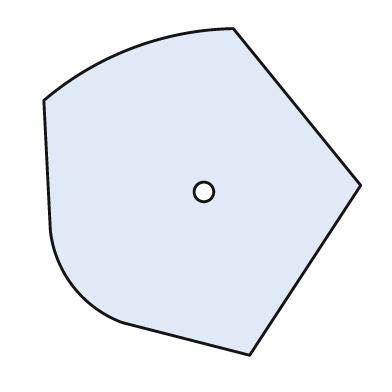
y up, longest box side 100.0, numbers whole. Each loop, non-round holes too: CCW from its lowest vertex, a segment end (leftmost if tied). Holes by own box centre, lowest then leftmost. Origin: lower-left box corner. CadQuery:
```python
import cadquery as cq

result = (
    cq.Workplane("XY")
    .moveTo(63.0, 0.0)
    .lineTo(97.0, 52.0)
    .lineTo(58.0, 100.0)
    .threePointArc((27.0, 94.0), (0.0, 78.0))
    .lineTo(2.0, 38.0)
    .threePointArc((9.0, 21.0), (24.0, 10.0))
    .close()
    .moveTo(49.0, 50.0)
    .circle(3.0)
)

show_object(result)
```